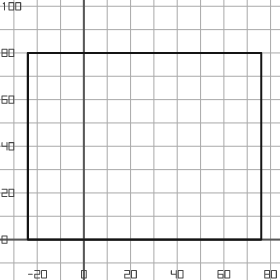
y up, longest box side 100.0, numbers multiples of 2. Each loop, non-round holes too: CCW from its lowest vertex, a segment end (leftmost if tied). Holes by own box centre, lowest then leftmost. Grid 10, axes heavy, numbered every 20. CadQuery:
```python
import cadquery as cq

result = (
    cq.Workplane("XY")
    .moveTo(-24.0, 0.0)
    .lineTo(76.0, 0.0)
    .lineTo(76.0, 80.0)
    .lineTo(-24.0, 80.0)
    .close()
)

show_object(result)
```